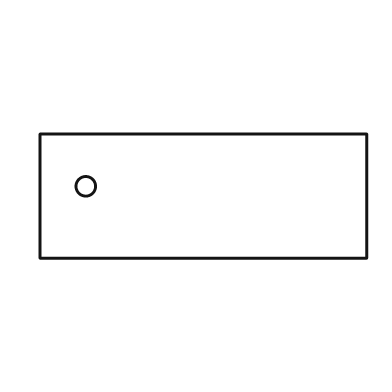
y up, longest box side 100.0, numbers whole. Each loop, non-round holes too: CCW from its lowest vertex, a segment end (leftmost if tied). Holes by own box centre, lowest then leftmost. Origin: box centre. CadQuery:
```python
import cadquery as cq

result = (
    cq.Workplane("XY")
    .moveTo(-50.0, -19.0)
    .lineTo(50.0, -19.0)
    .lineTo(50.0, 19.0)
    .lineTo(-50.0, 19.0)
    .close()
    .moveTo(-36.0, 3.0)
    .circle(3.0)
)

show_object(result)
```